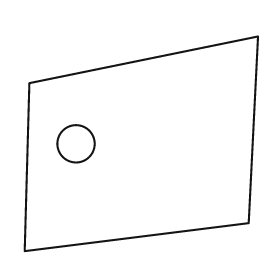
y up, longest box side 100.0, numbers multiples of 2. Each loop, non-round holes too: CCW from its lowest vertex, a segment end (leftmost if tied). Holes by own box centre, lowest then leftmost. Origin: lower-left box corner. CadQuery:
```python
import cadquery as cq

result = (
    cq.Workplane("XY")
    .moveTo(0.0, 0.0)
    .lineTo(96.0, 12.0)
    .lineTo(100.0, 92.0)
    .lineTo(2.0, 72.0)
    .close()
    .moveTo(22.0, 46.0)
    .circle(8.0)
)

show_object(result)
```